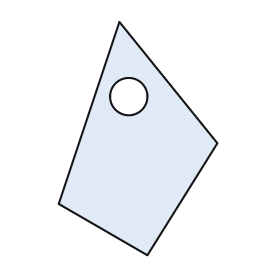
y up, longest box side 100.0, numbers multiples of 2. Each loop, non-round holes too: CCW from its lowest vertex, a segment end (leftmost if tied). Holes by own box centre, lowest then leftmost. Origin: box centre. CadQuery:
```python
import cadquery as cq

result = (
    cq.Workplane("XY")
    .moveTo(4.0, -50.0)
    .lineTo(34.0, -2.0)
    .lineTo(-8.0, 50.0)
    .lineTo(-34.0, -28.0)
    .close()
    .moveTo(-4.0, 18.0)
    .circle(8.0)
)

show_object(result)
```